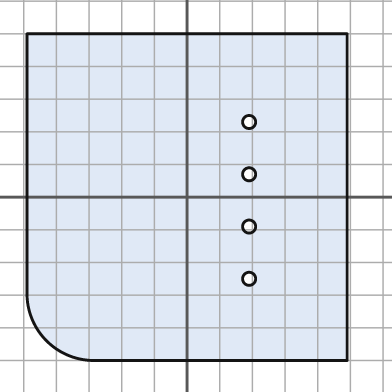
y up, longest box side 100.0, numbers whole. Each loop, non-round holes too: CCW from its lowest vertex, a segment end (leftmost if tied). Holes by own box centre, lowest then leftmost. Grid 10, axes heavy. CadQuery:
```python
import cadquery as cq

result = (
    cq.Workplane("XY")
    .moveTo(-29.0, -50.0)
    .lineTo(49.0, -50.0)
    .lineTo(49.0, 50.0)
    .lineTo(-49.0, 50.0)
    .lineTo(-49.0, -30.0)
    .threePointArc((-43.0, -44.0), (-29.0, -50.0))
    .close()
    .moveTo(19.0, -25.0)
    .circle(2.0)
    .moveTo(19.0, -9.0)
    .circle(2.0)
    .moveTo(19.0, 7.0)
    .circle(2.0)
    .moveTo(19.0, 23.0)
    .circle(2.0)
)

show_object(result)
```